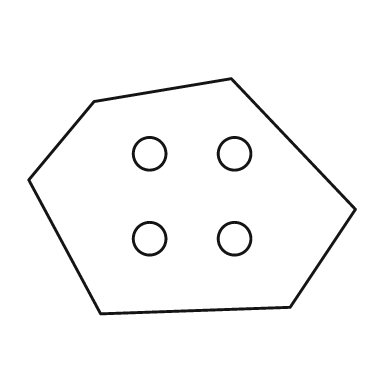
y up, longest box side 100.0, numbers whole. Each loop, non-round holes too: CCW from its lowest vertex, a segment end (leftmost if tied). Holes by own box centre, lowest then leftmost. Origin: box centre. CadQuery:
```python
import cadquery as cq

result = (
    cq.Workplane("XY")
    .moveTo(-28.0, -36.0)
    .lineTo(30.0, -34.0)
    .lineTo(50.0, -4.0)
    .lineTo(12.0, 36.0)
    .lineTo(-30.0, 29.0)
    .lineTo(-50.0, 5.0)
    .close()
    .moveTo(-13.0, -13.0)
    .circle(5.0)
    .moveTo(13.0, -13.0)
    .circle(5.0)
    .moveTo(-13.0, 13.0)
    .circle(5.0)
    .moveTo(13.0, 13.0)
    .circle(5.0)
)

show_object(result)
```